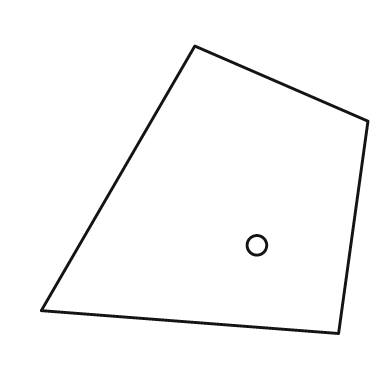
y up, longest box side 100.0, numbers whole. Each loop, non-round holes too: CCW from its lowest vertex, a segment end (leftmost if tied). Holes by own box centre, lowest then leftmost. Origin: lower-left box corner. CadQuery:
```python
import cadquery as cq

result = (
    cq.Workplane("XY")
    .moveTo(91.0, 0.0)
    .lineTo(100.0, 65.0)
    .lineTo(47.0, 88.0)
    .lineTo(0.0, 7.0)
    .close()
    .moveTo(66.0, 27.0)
    .circle(3.0)
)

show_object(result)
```